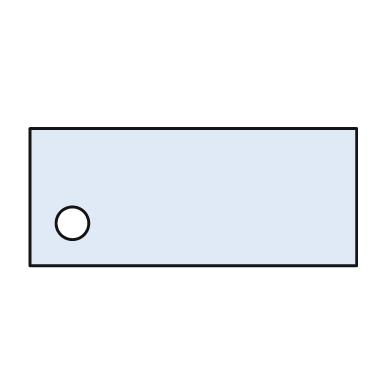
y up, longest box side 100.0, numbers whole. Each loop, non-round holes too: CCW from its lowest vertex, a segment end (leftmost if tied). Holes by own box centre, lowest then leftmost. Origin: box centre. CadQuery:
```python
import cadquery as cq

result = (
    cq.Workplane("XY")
    .moveTo(-50.0, -21.0)
    .lineTo(50.0, -21.0)
    .lineTo(50.0, 21.0)
    .lineTo(-50.0, 21.0)
    .close()
    .moveTo(-37.0, -8.0)
    .circle(5.0)
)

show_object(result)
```